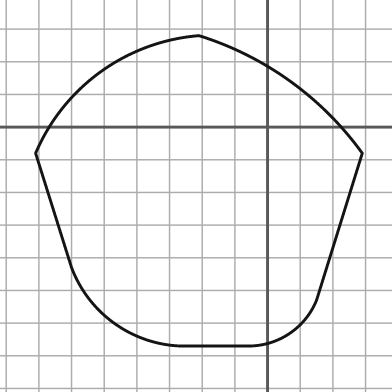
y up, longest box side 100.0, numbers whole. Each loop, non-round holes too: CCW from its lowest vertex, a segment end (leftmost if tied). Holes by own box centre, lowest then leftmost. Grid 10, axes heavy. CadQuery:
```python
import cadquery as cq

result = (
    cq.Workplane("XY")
    .moveTo(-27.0, -67.0)
    .lineTo(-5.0, -67.0)
    .threePointArc((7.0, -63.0), (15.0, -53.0))
    .lineTo(29.0, -8.0)
    .threePointArc((7.0, 14.0), (-21.0, 28.0))
    .threePointArc((-51.0, 17.0), (-71.0, -8.0))
    .lineTo(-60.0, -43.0)
    .threePointArc((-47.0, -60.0), (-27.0, -67.0))
    .close()
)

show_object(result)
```